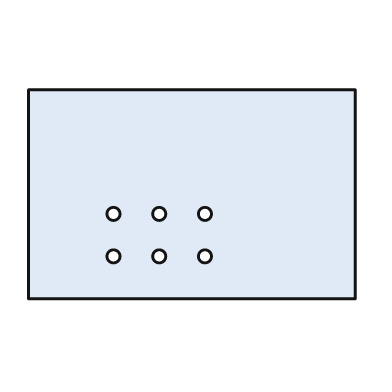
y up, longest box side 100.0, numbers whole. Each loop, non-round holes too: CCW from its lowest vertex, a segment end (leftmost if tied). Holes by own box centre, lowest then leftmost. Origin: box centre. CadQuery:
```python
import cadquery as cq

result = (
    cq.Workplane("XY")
    .moveTo(-50.0, -32.0)
    .lineTo(50.0, -32.0)
    .lineTo(50.0, 32.0)
    .lineTo(-50.0, 32.0)
    .close()
    .moveTo(-24.0, -19.0)
    .circle(2.0)
    .moveTo(-10.0, -19.0)
    .circle(2.0)
    .moveTo(4.0, -19.0)
    .circle(2.0)
    .moveTo(-24.0, -6.0)
    .circle(2.0)
    .moveTo(-10.0, -6.0)
    .circle(2.0)
    .moveTo(4.0, -6.0)
    .circle(2.0)
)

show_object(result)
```